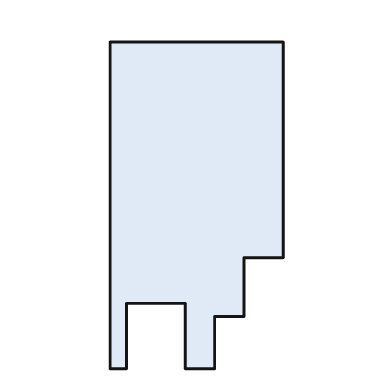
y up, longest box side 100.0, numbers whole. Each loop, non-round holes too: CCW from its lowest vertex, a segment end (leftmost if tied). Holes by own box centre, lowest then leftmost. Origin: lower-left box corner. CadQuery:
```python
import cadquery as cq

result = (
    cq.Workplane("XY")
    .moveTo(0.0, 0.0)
    .lineTo(5.0, 0.0)
    .lineTo(5.0, 20.0)
    .lineTo(23.0, 20.0)
    .lineTo(23.0, 0.0)
    .lineTo(32.0, 0.0)
    .lineTo(32.0, 16.0)
    .lineTo(41.0, 16.0)
    .lineTo(41.0, 34.0)
    .lineTo(53.0, 34.0)
    .lineTo(53.0, 100.0)
    .lineTo(0.0, 100.0)
    .close()
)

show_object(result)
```